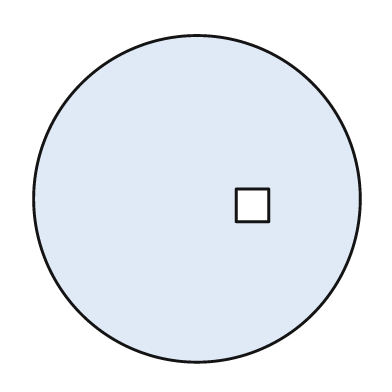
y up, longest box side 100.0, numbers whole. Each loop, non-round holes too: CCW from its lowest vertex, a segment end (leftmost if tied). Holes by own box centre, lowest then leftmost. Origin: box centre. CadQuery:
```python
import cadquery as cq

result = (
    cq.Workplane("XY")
    .moveTo(0.0, 0.0)
    .circle(50.0)
    .moveTo(12.0, -7.0)
    .lineTo(22.0, -7.0)
    .lineTo(22.0, 3.0)
    .lineTo(12.0, 3.0)
    .close()
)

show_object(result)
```